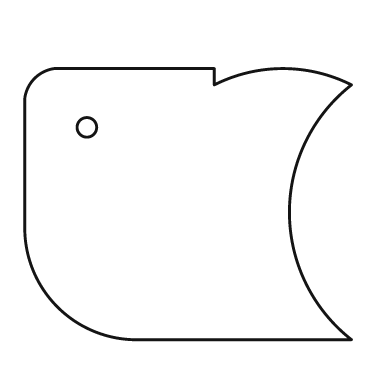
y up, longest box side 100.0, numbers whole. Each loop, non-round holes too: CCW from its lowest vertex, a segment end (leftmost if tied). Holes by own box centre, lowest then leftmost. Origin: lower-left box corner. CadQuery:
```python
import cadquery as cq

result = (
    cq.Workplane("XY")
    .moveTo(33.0, 0.0)
    .lineTo(100.0, 0.0)
    .threePointArc((81.0, 39.0), (100.0, 78.0))
    .threePointArc((79.0, 83.0), (58.0, 78.0))
    .lineTo(58.0, 83.0)
    .lineTo(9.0, 83.0)
    .threePointArc((3.0, 80.0), (0.0, 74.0))
    .lineTo(0.0, 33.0)
    .threePointArc((10.0, 10.0), (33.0, 0.0))
    .close()
    .moveTo(19.0, 65.0)
    .circle(3.0)
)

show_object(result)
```